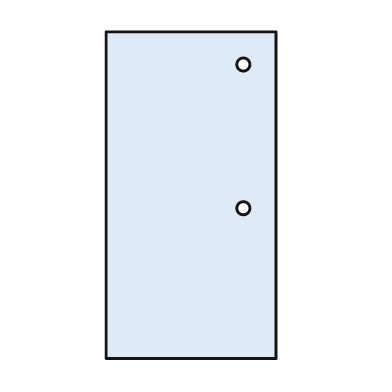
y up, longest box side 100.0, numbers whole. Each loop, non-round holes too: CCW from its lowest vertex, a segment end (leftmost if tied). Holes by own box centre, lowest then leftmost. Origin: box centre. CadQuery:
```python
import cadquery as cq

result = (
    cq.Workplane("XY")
    .moveTo(-26.0, -50.0)
    .lineTo(26.0, -50.0)
    .lineTo(26.0, 50.0)
    .lineTo(-26.0, 50.0)
    .close()
    .moveTo(16.0, -4.0)
    .circle(2.0)
    .moveTo(16.0, 40.0)
    .circle(2.0)
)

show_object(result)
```